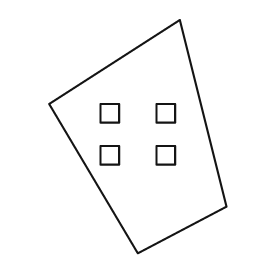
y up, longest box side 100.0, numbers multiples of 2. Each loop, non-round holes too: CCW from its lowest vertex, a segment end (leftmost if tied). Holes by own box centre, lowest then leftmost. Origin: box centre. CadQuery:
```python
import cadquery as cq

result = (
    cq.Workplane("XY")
    .moveTo(0.0, -50.0)
    .lineTo(38.0, -30.0)
    .lineTo(18.0, 50.0)
    .lineTo(-38.0, 14.0)
    .close()
    .moveTo(-16.0, -12.0)
    .lineTo(-8.0, -12.0)
    .lineTo(-8.0, -4.0)
    .lineTo(-16.0, -4.0)
    .close()
    .moveTo(8.0, -12.0)
    .lineTo(16.0, -12.0)
    .lineTo(16.0, -4.0)
    .lineTo(8.0, -4.0)
    .close()
    .moveTo(-16.0, 6.0)
    .lineTo(-8.0, 6.0)
    .lineTo(-8.0, 14.0)
    .lineTo(-16.0, 14.0)
    .close()
    .moveTo(8.0, 6.0)
    .lineTo(16.0, 6.0)
    .lineTo(16.0, 14.0)
    .lineTo(8.0, 14.0)
    .close()
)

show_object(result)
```